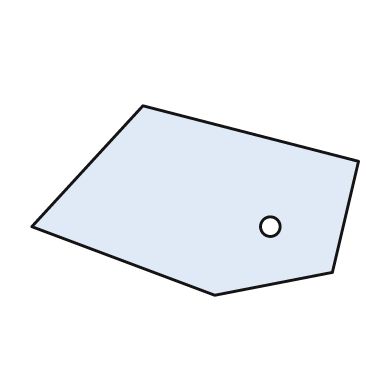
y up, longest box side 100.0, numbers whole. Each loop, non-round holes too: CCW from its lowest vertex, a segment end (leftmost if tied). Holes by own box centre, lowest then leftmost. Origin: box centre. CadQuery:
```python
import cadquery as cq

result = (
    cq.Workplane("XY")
    .moveTo(6.0, -29.0)
    .lineTo(42.0, -22.0)
    .lineTo(50.0, 12.0)
    .lineTo(-16.0, 29.0)
    .lineTo(-50.0, -8.0)
    .close()
    .moveTo(23.0, -8.0)
    .circle(3.0)
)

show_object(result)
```